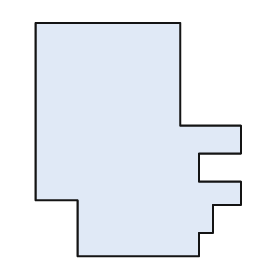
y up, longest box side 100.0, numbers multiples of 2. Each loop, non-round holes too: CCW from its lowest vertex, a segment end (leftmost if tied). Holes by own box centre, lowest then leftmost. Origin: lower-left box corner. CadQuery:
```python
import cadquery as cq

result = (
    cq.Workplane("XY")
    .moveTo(18.0, 0.0)
    .lineTo(70.0, 0.0)
    .lineTo(70.0, 10.0)
    .lineTo(76.0, 10.0)
    .lineTo(76.0, 22.0)
    .lineTo(88.0, 22.0)
    .lineTo(88.0, 32.0)
    .lineTo(70.0, 32.0)
    .lineTo(70.0, 44.0)
    .lineTo(88.0, 44.0)
    .lineTo(88.0, 56.0)
    .lineTo(62.0, 56.0)
    .lineTo(62.0, 100.0)
    .lineTo(0.0, 100.0)
    .lineTo(0.0, 24.0)
    .lineTo(18.0, 24.0)
    .close()
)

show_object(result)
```